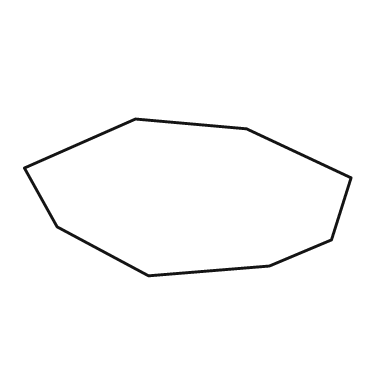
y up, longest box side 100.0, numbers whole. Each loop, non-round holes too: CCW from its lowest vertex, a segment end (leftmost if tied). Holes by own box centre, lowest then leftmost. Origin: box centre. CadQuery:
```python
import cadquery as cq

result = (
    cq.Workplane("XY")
    .moveTo(-12.0, -24.0)
    .lineTo(25.0, -21.0)
    .lineTo(44.0, -13.0)
    .lineTo(50.0, 6.0)
    .lineTo(18.0, 21.0)
    .lineTo(-16.0, 24.0)
    .lineTo(-50.0, 9.0)
    .lineTo(-40.0, -9.0)
    .close()
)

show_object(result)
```